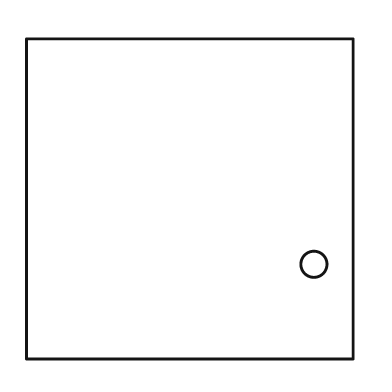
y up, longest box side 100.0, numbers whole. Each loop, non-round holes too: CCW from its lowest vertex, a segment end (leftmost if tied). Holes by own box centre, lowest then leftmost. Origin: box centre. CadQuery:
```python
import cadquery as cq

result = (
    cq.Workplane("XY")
    .moveTo(-50.0, -49.0)
    .lineTo(50.0, -49.0)
    .lineTo(50.0, 49.0)
    .lineTo(-50.0, 49.0)
    .close()
    .moveTo(38.0, -20.0)
    .circle(4.0)
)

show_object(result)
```